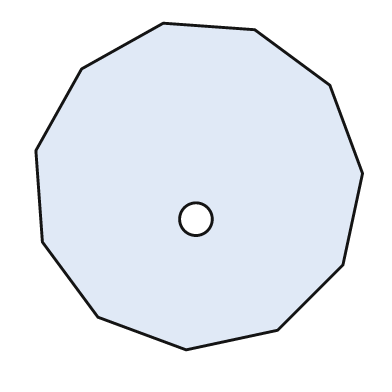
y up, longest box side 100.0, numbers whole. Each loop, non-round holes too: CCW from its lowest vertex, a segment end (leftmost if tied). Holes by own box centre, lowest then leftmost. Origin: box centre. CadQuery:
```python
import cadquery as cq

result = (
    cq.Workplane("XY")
    .moveTo(-4.0, -50.0)
    .lineTo(24.0, -44.0)
    .lineTo(44.0, -24.0)
    .lineTo(50.0, 4.0)
    .lineTo(40.0, 31.0)
    .lineTo(17.0, 48.0)
    .lineTo(-11.0, 50.0)
    .lineTo(-36.0, 36.0)
    .lineTo(-50.0, 11.0)
    .lineTo(-48.0, -17.0)
    .lineTo(-31.0, -40.0)
    .close()
    .moveTo(-1.0, -10.0)
    .circle(5.0)
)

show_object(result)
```